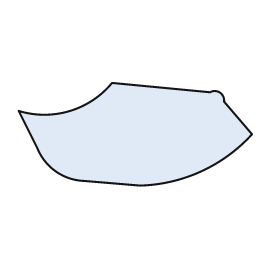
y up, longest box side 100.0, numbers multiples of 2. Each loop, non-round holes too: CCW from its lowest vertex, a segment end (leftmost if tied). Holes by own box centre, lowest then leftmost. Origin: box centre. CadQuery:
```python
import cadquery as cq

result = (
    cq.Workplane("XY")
    .moveTo(2.0, -22.0)
    .threePointArc((28.0, -16.0), (50.0, 0.0))
    .lineTo(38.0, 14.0)
    .threePointArc((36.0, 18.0), (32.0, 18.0))
    .lineTo(-10.0, 22.0)
    .threePointArc((-28.0, 10.0), (-50.0, 10.0))
    .lineTo(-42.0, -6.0)
    .threePointArc((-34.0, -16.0), (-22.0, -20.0))
    .close()
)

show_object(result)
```